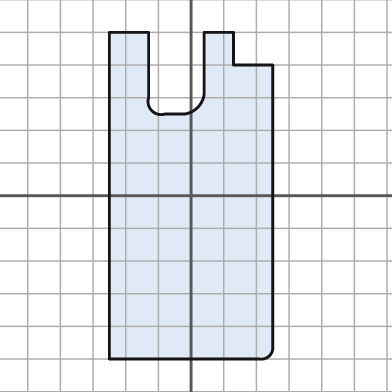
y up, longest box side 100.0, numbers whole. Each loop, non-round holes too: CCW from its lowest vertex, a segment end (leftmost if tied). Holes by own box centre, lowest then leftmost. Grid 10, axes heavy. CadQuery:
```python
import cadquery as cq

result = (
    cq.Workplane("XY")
    .moveTo(-25.0, -50.0)
    .lineTo(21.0, -50.0)
    .threePointArc((24.0, -49.0), (25.0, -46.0))
    .lineTo(25.0, 40.0)
    .lineTo(13.0, 40.0)
    .lineTo(13.0, 50.0)
    .lineTo(4.0, 50.0)
    .lineTo(4.0, 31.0)
    .threePointArc((2.0, 27.0), (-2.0, 25.0))
    .lineTo(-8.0, 25.0)
    .threePointArc((-12.0, 26.0), (-13.0, 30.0))
    .lineTo(-13.0, 50.0)
    .lineTo(-25.0, 50.0)
    .close()
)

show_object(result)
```